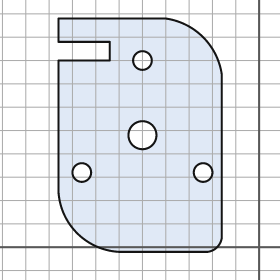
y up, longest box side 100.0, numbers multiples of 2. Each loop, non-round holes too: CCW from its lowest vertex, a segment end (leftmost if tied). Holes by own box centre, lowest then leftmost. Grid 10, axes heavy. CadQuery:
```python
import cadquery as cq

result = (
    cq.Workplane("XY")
    .moveTo(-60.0, -2.0)
    .lineTo(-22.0, -2.0)
    .threePointArc((-18.0, 0.0), (-16.0, 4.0))
    .lineTo(-16.0, 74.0)
    .threePointArc((-24.0, 90.0), (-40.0, 98.0))
    .lineTo(-86.0, 98.0)
    .lineTo(-86.0, 88.0)
    .lineTo(-64.0, 88.0)
    .lineTo(-64.0, 80.0)
    .lineTo(-86.0, 80.0)
    .lineTo(-86.0, 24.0)
    .threePointArc((-78.0, 6.0), (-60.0, -2.0))
    .close()
    .moveTo(-76.0, 32.0)
    .circle(4.0)
    .moveTo(-24.0, 32.0)
    .circle(4.0)
    .moveTo(-50.0, 48.0)
    .circle(6.0)
    .moveTo(-50.0, 80.0)
    .circle(4.0)
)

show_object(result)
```